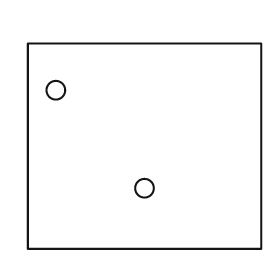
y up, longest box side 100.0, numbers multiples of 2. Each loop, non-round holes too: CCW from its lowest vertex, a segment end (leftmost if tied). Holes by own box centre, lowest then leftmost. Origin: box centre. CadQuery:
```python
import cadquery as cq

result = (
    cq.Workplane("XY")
    .moveTo(-50.0, -44.0)
    .lineTo(50.0, -44.0)
    .lineTo(50.0, 44.0)
    .lineTo(-50.0, 44.0)
    .close()
    .moveTo(0.0, -18.0)
    .circle(4.0)
    .moveTo(-38.0, 24.0)
    .circle(4.0)
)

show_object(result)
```